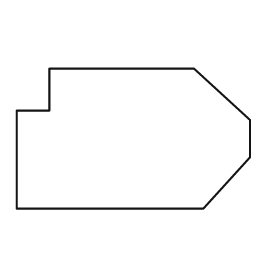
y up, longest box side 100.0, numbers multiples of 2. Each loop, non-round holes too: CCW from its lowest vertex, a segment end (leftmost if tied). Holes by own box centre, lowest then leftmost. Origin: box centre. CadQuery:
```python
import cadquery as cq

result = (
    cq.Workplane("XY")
    .moveTo(-50.0, -30.0)
    .lineTo(30.0, -30.0)
    .lineTo(50.0, -8.0)
    .lineTo(50.0, 8.0)
    .lineTo(26.0, 30.0)
    .lineTo(-36.0, 30.0)
    .lineTo(-36.0, 12.0)
    .lineTo(-50.0, 12.0)
    .close()
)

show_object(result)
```